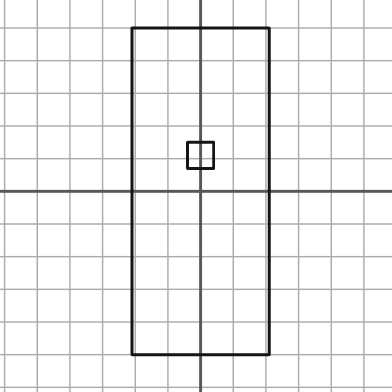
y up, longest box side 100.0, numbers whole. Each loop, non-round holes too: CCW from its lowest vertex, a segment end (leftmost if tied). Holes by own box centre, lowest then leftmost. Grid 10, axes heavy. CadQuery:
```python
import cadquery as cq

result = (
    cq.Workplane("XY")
    .moveTo(-21.0, -50.0)
    .lineTo(21.0, -50.0)
    .lineTo(21.0, 50.0)
    .lineTo(-21.0, 50.0)
    .close()
    .moveTo(-4.0, 7.0)
    .lineTo(4.0, 7.0)
    .lineTo(4.0, 15.0)
    .lineTo(-4.0, 15.0)
    .close()
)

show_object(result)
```